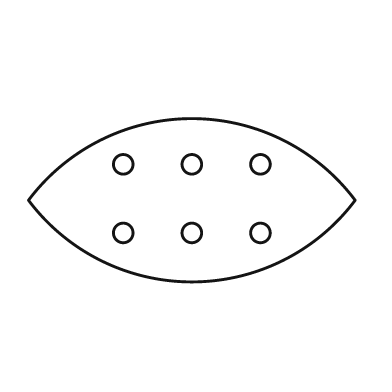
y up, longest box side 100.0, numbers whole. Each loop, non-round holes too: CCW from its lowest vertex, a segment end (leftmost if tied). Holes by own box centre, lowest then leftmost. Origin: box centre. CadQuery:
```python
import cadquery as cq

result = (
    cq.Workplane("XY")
    .moveTo(-50.0, 0.0)
    .threePointArc((0.0, -25.0), (50.0, 0.0))
    .threePointArc((0.0, 25.0), (-50.0, 0.0))
    .close()
    .moveTo(-21.0, -10.0)
    .circle(3.0)
    .moveTo(0.0, -10.0)
    .circle(3.0)
    .moveTo(21.0, -10.0)
    .circle(3.0)
    .moveTo(-21.0, 11.0)
    .circle(3.0)
    .moveTo(0.0, 11.0)
    .circle(3.0)
    .moveTo(21.0, 11.0)
    .circle(3.0)
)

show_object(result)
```